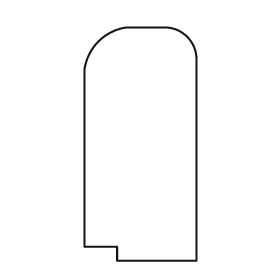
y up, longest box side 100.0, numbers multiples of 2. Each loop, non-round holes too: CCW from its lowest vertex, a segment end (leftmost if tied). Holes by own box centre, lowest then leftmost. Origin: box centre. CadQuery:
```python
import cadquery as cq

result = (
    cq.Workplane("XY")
    .moveTo(-10.0, -50.0)
    .lineTo(24.0, -50.0)
    .lineTo(24.0, 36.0)
    .threePointArc((20.0, 46.0), (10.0, 50.0))
    .lineTo(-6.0, 50.0)
    .threePointArc((-18.0, 44.0), (-24.0, 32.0))
    .lineTo(-24.0, -44.0)
    .lineTo(-10.0, -44.0)
    .close()
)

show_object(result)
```